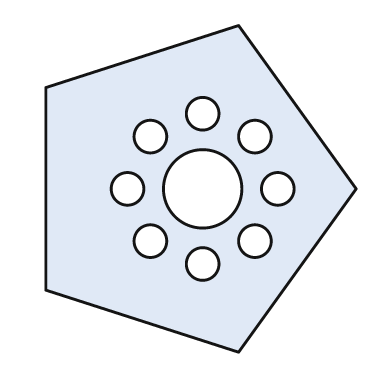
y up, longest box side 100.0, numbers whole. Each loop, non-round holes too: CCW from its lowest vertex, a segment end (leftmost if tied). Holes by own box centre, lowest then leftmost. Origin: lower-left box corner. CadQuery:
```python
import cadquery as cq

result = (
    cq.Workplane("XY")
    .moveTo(59.0, 0.0)
    .lineTo(95.0, 50.0)
    .lineTo(59.0, 100.0)
    .lineTo(0.0, 81.0)
    .lineTo(0.0, 19.0)
    .close()
    .moveTo(48.0, 27.0)
    .circle(5.0)
    .moveTo(32.0, 34.0)
    .circle(5.0)
    .moveTo(64.0, 34.0)
    .circle(5.0)
    .moveTo(25.0, 50.0)
    .circle(5.0)
    .moveTo(48.0, 50.0)
    .circle(12.0)
    .moveTo(71.0, 50.0)
    .circle(5.0)
    .moveTo(32.0, 66.0)
    .circle(5.0)
    .moveTo(64.0, 66.0)
    .circle(5.0)
    .moveTo(48.0, 73.0)
    .circle(5.0)
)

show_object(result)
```